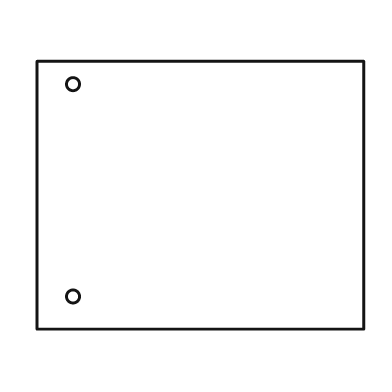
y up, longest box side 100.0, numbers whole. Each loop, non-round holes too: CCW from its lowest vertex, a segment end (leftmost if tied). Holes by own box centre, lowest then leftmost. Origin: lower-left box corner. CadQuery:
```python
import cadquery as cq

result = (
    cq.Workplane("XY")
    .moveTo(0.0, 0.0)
    .lineTo(100.0, 0.0)
    .lineTo(100.0, 82.0)
    .lineTo(0.0, 82.0)
    .close()
    .moveTo(11.0, 10.0)
    .circle(2.0)
    .moveTo(11.0, 75.0)
    .circle(2.0)
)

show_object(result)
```